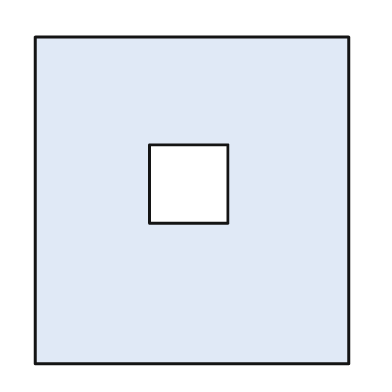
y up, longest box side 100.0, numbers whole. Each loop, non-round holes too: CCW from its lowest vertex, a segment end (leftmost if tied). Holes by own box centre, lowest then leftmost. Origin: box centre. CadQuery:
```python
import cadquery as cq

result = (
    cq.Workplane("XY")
    .moveTo(-48.0, -50.0)
    .lineTo(48.0, -50.0)
    .lineTo(48.0, 50.0)
    .lineTo(-48.0, 50.0)
    .close()
    .moveTo(-13.0, -7.0)
    .lineTo(11.0, -7.0)
    .lineTo(11.0, 17.0)
    .lineTo(-13.0, 17.0)
    .close()
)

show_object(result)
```